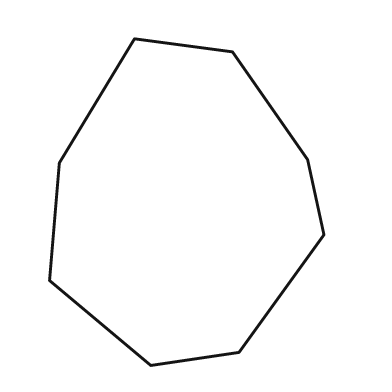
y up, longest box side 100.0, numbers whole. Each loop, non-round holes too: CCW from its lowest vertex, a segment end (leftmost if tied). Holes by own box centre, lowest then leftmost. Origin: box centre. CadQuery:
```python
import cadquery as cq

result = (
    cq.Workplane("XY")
    .moveTo(-11.0, -50.0)
    .lineTo(16.0, -46.0)
    .lineTo(42.0, -10.0)
    .lineTo(37.0, 13.0)
    .lineTo(14.0, 46.0)
    .lineTo(-16.0, 50.0)
    .lineTo(-39.0, 12.0)
    .lineTo(-42.0, -24.0)
    .close()
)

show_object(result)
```